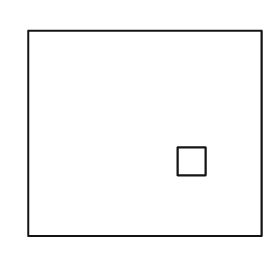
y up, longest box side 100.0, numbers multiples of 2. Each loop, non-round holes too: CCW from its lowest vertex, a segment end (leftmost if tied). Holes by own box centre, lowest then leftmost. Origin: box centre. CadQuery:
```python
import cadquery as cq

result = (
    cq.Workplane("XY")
    .moveTo(-50.0, -44.0)
    .lineTo(50.0, -44.0)
    .lineTo(50.0, 44.0)
    .lineTo(-50.0, 44.0)
    .close()
    .moveTo(14.0, -18.0)
    .lineTo(26.0, -18.0)
    .lineTo(26.0, -6.0)
    .lineTo(14.0, -6.0)
    .close()
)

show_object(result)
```